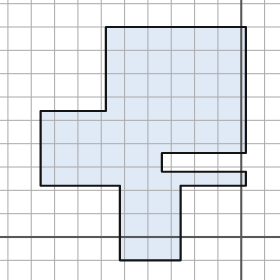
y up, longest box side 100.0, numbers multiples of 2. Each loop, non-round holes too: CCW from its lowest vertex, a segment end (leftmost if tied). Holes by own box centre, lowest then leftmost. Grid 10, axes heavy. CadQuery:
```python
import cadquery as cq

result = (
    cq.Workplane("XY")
    .moveTo(-52.0, -10.0)
    .lineTo(-26.0, -10.0)
    .lineTo(-26.0, 22.0)
    .lineTo(2.0, 22.0)
    .lineTo(2.0, 28.0)
    .lineTo(-34.0, 28.0)
    .lineTo(-34.0, 36.0)
    .lineTo(2.0, 36.0)
    .lineTo(2.0, 90.0)
    .lineTo(-58.0, 90.0)
    .lineTo(-58.0, 54.0)
    .lineTo(-86.0, 54.0)
    .lineTo(-86.0, 22.0)
    .lineTo(-52.0, 22.0)
    .close()
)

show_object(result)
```